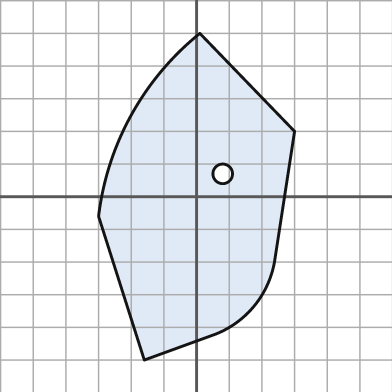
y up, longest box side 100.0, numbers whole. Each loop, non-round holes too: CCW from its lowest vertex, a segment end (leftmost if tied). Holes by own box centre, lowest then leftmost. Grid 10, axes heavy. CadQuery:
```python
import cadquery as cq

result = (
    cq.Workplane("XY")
    .moveTo(-16.0, -50.0)
    .lineTo(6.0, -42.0)
    .threePointArc((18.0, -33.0), (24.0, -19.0))
    .lineTo(30.0, 20.0)
    .lineTo(1.0, 50.0)
    .threePointArc((-20.0, 25.0), (-30.0, -6.0))
    .close()
    .moveTo(8.0, 7.0)
    .circle(3.0)
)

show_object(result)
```